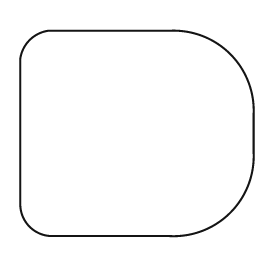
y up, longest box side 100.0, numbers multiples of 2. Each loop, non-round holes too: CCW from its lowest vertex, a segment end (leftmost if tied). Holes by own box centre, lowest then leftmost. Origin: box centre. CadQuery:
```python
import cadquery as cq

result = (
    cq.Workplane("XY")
    .moveTo(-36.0, -44.0)
    .lineTo(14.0, -44.0)
    .threePointArc((40.0, -34.0), (50.0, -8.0))
    .lineTo(50.0, 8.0)
    .threePointArc((40.0, 34.0), (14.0, 44.0))
    .lineTo(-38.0, 44.0)
    .threePointArc((-46.0, 40.0), (-50.0, 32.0))
    .lineTo(-50.0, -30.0)
    .threePointArc((-46.0, -40.0), (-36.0, -44.0))
    .close()
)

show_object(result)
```